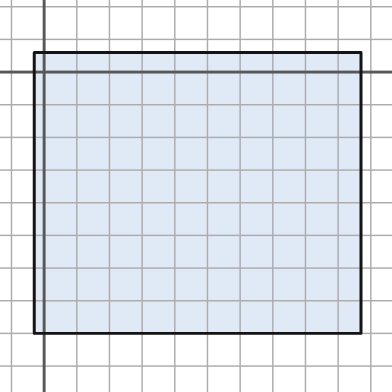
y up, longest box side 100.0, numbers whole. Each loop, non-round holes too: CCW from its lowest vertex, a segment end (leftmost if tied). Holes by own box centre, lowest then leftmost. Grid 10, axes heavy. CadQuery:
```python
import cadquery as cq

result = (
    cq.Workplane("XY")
    .moveTo(-3.0, -80.0)
    .lineTo(97.0, -80.0)
    .lineTo(97.0, 6.0)
    .lineTo(-3.0, 6.0)
    .close()
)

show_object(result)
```